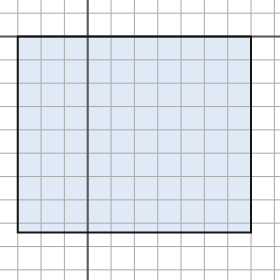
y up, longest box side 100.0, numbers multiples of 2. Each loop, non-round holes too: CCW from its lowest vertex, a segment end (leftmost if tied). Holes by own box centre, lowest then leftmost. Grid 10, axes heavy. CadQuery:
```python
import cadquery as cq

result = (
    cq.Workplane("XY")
    .moveTo(-30.0, -84.0)
    .lineTo(70.0, -84.0)
    .lineTo(70.0, 0.0)
    .lineTo(-30.0, 0.0)
    .close()
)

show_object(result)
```